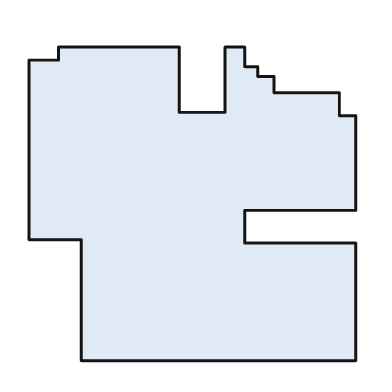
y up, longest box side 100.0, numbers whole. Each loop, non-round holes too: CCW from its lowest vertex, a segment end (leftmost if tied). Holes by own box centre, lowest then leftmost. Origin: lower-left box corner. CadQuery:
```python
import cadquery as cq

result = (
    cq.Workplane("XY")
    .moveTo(16.0, 0.0)
    .lineTo(100.0, 0.0)
    .lineTo(100.0, 36.0)
    .lineTo(66.0, 36.0)
    .lineTo(66.0, 46.0)
    .lineTo(100.0, 46.0)
    .lineTo(100.0, 75.0)
    .lineTo(95.0, 75.0)
    .lineTo(95.0, 82.0)
    .lineTo(75.0, 82.0)
    .lineTo(75.0, 87.0)
    .lineTo(70.0, 87.0)
    .lineTo(70.0, 90.0)
    .lineTo(66.0, 90.0)
    .lineTo(66.0, 96.0)
    .lineTo(60.0, 96.0)
    .lineTo(60.0, 76.0)
    .lineTo(46.0, 76.0)
    .lineTo(46.0, 96.0)
    .lineTo(9.0, 96.0)
    .lineTo(9.0, 92.0)
    .lineTo(0.0, 92.0)
    .lineTo(0.0, 37.0)
    .lineTo(16.0, 37.0)
    .close()
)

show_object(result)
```